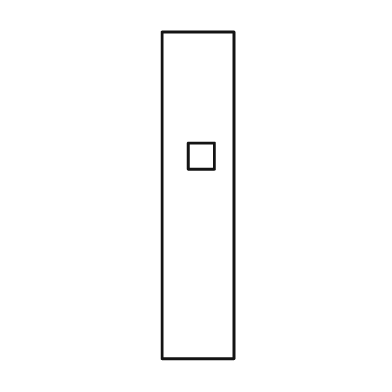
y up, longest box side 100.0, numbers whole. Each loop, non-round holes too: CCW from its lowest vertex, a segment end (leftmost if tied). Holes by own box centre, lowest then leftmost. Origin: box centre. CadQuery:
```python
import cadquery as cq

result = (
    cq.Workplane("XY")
    .moveTo(-11.0, -50.0)
    .lineTo(11.0, -50.0)
    .lineTo(11.0, 50.0)
    .lineTo(-11.0, 50.0)
    .close()
    .moveTo(-3.0, 8.0)
    .lineTo(5.0, 8.0)
    .lineTo(5.0, 16.0)
    .lineTo(-3.0, 16.0)
    .close()
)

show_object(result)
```